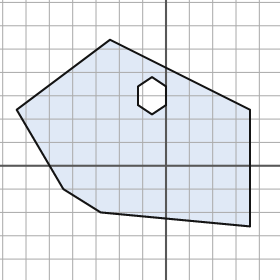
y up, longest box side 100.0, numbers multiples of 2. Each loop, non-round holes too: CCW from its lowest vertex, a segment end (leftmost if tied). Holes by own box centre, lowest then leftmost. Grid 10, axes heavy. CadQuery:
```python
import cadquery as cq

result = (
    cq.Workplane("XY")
    .moveTo(36.0, -26.0)
    .lineTo(36.0, 24.0)
    .lineTo(-24.0, 54.0)
    .lineTo(-64.0, 24.0)
    .lineTo(-44.0, -10.0)
    .lineTo(-28.0, -20.0)
    .close()
    .moveTo(-6.0, 22.0)
    .lineTo(0.0, 26.0)
    .lineTo(0.0, 34.0)
    .lineTo(-6.0, 38.0)
    .lineTo(-12.0, 34.0)
    .lineTo(-12.0, 26.0)
    .close()
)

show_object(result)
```